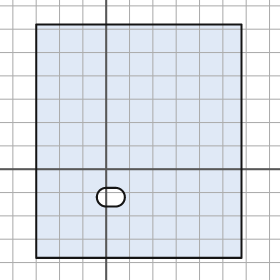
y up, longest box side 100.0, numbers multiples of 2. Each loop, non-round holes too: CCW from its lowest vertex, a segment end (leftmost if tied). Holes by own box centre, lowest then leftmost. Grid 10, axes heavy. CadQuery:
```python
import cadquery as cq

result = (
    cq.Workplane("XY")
    .moveTo(-30.0, -38.0)
    .lineTo(58.0, -38.0)
    .lineTo(58.0, 62.0)
    .lineTo(-30.0, 62.0)
    .close()
    .moveTo(0.0, -16.0)
    .lineTo(4.0, -16.0)
    .threePointArc((8.0, -12.0), (4.0, -8.0))
    .lineTo(0.0, -8.0)
    .threePointArc((-4.0, -12.0), (0.0, -16.0))
    .close()
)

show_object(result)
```